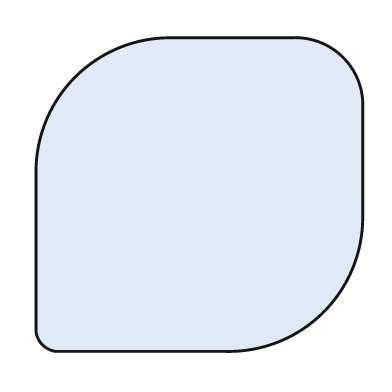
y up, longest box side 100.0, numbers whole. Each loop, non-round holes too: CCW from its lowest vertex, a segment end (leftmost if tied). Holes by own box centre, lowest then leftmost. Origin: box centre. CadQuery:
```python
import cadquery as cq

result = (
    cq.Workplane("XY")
    .moveTo(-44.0, -48.0)
    .lineTo(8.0, -48.0)
    .threePointArc((38.0, -36.0), (50.0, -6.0))
    .lineTo(50.0, 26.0)
    .threePointArc((44.0, 42.0), (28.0, 48.0))
    .lineTo(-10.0, 48.0)
    .threePointArc((-38.0, 36.0), (-50.0, 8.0))
    .lineTo(-50.0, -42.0)
    .threePointArc((-48.0, -46.0), (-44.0, -48.0))
    .close()
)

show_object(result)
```